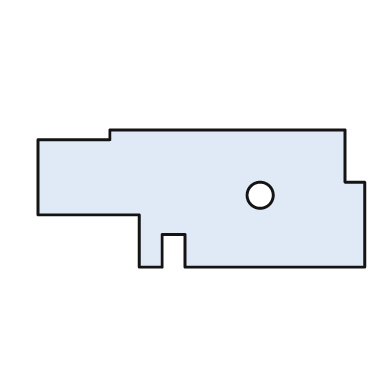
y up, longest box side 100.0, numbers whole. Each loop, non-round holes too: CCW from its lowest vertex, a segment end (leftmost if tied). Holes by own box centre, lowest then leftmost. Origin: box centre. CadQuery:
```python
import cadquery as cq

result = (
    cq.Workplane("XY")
    .moveTo(-19.0, -21.0)
    .lineTo(-12.0, -21.0)
    .lineTo(-12.0, -11.0)
    .lineTo(-5.0, -11.0)
    .lineTo(-5.0, -21.0)
    .lineTo(50.0, -21.0)
    .lineTo(50.0, 5.0)
    .lineTo(44.0, 5.0)
    .lineTo(44.0, 21.0)
    .lineTo(-28.0, 21.0)
    .lineTo(-28.0, 18.0)
    .lineTo(-50.0, 18.0)
    .lineTo(-50.0, -5.0)
    .lineTo(-19.0, -5.0)
    .close()
    .moveTo(18.0, 1.0)
    .circle(4.0)
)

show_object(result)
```